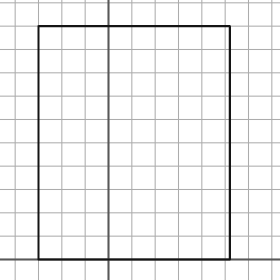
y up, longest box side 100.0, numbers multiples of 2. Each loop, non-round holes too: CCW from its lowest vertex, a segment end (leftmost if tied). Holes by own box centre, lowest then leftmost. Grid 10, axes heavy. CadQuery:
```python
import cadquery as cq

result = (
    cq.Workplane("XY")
    .moveTo(-30.0, 0.0)
    .lineTo(52.0, 0.0)
    .lineTo(52.0, 100.0)
    .lineTo(-30.0, 100.0)
    .close()
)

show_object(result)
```